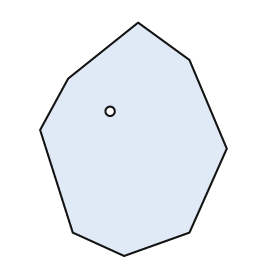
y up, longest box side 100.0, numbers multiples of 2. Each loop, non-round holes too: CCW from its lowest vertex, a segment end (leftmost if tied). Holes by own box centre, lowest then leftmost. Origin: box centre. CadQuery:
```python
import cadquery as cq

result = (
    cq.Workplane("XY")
    .moveTo(-4.0, -50.0)
    .lineTo(24.0, -40.0)
    .lineTo(40.0, -4.0)
    .lineTo(24.0, 34.0)
    .lineTo(2.0, 50.0)
    .lineTo(-28.0, 26.0)
    .lineTo(-40.0, 4.0)
    .lineTo(-26.0, -40.0)
    .close()
    .moveTo(-10.0, 12.0)
    .circle(2.0)
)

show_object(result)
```